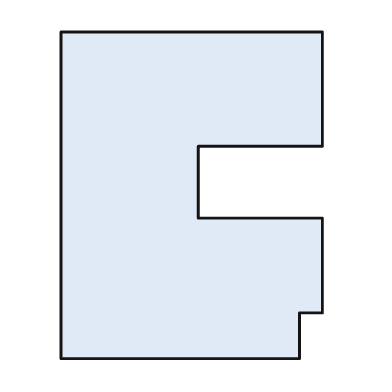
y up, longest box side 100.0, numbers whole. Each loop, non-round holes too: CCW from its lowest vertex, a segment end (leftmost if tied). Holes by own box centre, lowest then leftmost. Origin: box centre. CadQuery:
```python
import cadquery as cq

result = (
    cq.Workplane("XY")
    .moveTo(-40.0, -50.0)
    .lineTo(33.0, -50.0)
    .lineTo(33.0, -36.0)
    .lineTo(40.0, -36.0)
    .lineTo(40.0, -7.0)
    .lineTo(2.0, -7.0)
    .lineTo(2.0, 15.0)
    .lineTo(40.0, 15.0)
    .lineTo(40.0, 50.0)
    .lineTo(-40.0, 50.0)
    .close()
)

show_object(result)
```